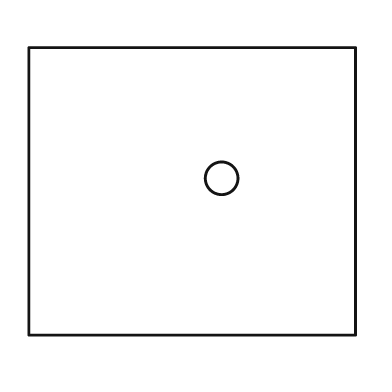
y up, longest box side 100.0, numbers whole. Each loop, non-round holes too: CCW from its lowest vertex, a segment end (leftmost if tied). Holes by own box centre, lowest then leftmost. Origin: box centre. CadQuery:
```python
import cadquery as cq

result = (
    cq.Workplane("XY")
    .moveTo(-50.0, -44.0)
    .lineTo(50.0, -44.0)
    .lineTo(50.0, 44.0)
    .lineTo(-50.0, 44.0)
    .close()
    .moveTo(9.0, 4.0)
    .circle(5.0)
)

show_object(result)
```